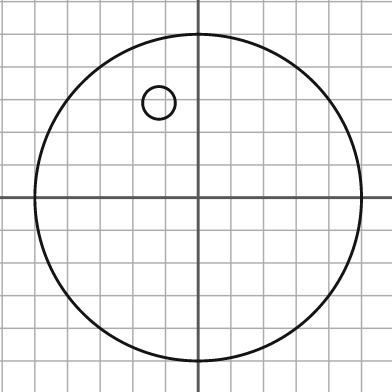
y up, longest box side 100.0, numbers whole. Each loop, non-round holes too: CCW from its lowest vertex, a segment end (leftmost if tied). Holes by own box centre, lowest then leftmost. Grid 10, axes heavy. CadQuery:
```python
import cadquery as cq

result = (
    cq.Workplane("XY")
    .moveTo(0.0, 0.0)
    .circle(50.0)
    .moveTo(-12.0, 29.0)
    .circle(5.0)
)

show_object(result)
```